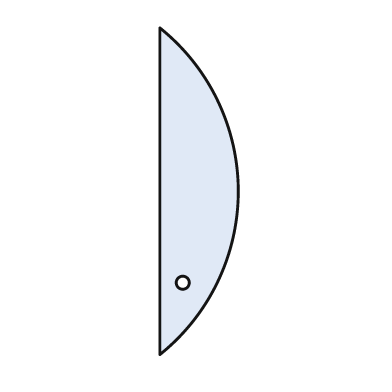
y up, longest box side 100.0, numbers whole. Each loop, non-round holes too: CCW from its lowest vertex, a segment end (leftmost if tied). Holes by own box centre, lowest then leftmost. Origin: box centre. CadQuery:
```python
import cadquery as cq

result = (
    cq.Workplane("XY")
    .moveTo(-12.0, -50.0)
    .threePointArc((12.0, 0.0), (-12.0, 50.0))
    .close()
    .moveTo(-5.0, -28.0)
    .circle(2.0)
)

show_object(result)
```